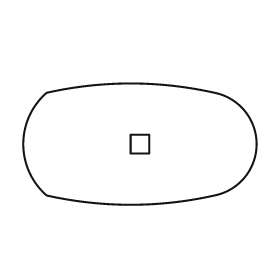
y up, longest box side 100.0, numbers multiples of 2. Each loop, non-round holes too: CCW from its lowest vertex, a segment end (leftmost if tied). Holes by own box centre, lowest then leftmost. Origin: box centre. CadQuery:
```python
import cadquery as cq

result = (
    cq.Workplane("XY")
    .moveTo(-40.0, -22.0)
    .threePointArc((-4.0, -26.0), (32.0, -22.0))
    .threePointArc((50.0, 0.0), (32.0, 22.0))
    .threePointArc((-4.0, 26.0), (-40.0, 22.0))
    .threePointArc((-50.0, 0.0), (-40.0, -22.0))
    .close()
    .moveTo(-4.0, -4.0)
    .lineTo(4.0, -4.0)
    .lineTo(4.0, 4.0)
    .lineTo(-4.0, 4.0)
    .close()
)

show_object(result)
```